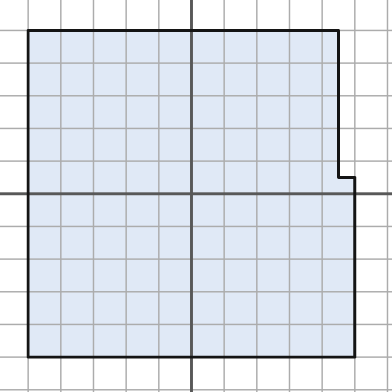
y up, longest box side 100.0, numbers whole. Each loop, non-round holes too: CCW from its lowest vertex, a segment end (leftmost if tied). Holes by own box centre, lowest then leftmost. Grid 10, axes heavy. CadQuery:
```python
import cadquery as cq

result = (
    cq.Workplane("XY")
    .moveTo(-50.0, -50.0)
    .lineTo(50.0, -50.0)
    .lineTo(50.0, 5.0)
    .lineTo(45.0, 5.0)
    .lineTo(45.0, 50.0)
    .lineTo(-50.0, 50.0)
    .close()
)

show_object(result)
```